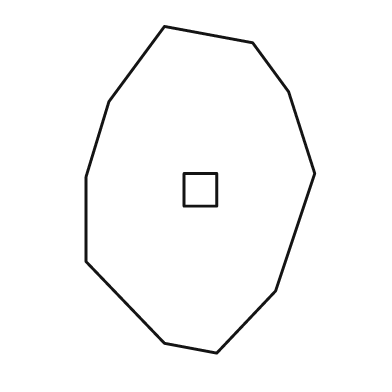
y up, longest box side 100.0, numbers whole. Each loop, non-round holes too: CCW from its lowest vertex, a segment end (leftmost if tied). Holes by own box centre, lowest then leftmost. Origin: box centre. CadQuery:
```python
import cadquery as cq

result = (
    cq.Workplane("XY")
    .moveTo(5.0, -50.0)
    .lineTo(23.0, -31.0)
    .lineTo(35.0, 5.0)
    .lineTo(27.0, 30.0)
    .lineTo(16.0, 45.0)
    .lineTo(-11.0, 50.0)
    .lineTo(-28.0, 27.0)
    .lineTo(-35.0, 4.0)
    .lineTo(-35.0, -22.0)
    .lineTo(-11.0, -47.0)
    .close()
    .moveTo(-5.0, -5.0)
    .lineTo(5.0, -5.0)
    .lineTo(5.0, 5.0)
    .lineTo(-5.0, 5.0)
    .close()
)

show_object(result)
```